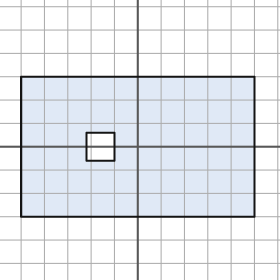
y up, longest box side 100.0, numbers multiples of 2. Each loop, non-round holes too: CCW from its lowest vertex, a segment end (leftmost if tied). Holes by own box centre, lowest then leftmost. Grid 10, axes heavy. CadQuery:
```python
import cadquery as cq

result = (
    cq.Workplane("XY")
    .moveTo(-50.0, -30.0)
    .lineTo(50.0, -30.0)
    .lineTo(50.0, 30.0)
    .lineTo(-50.0, 30.0)
    .close()
    .moveTo(-22.0, -6.0)
    .lineTo(-10.0, -6.0)
    .lineTo(-10.0, 6.0)
    .lineTo(-22.0, 6.0)
    .close()
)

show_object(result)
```